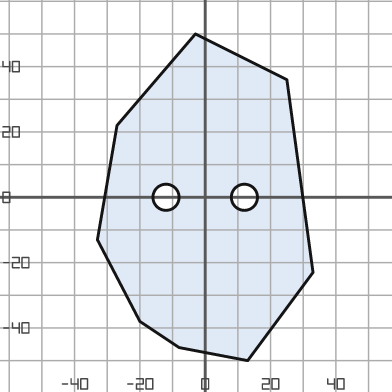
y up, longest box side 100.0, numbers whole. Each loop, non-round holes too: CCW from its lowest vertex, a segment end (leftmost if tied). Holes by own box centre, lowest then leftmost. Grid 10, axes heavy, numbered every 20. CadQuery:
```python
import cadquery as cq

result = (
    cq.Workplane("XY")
    .moveTo(13.0, -50.0)
    .lineTo(33.0, -23.0)
    .lineTo(25.0, 36.0)
    .lineTo(-3.0, 50.0)
    .lineTo(-27.0, 22.0)
    .lineTo(-33.0, -13.0)
    .lineTo(-20.0, -38.0)
    .lineTo(-8.0, -46.0)
    .close()
    .moveTo(-12.0, 0.0)
    .circle(4.0)
    .moveTo(12.0, 0.0)
    .circle(4.0)
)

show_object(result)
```